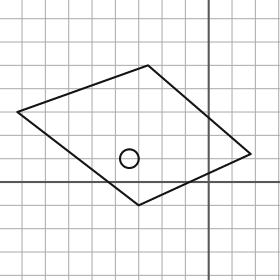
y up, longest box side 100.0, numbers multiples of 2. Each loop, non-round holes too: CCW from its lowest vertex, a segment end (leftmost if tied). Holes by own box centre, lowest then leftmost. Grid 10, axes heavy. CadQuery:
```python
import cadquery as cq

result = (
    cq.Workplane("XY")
    .moveTo(-30.0, -10.0)
    .lineTo(18.0, 12.0)
    .lineTo(-26.0, 50.0)
    .lineTo(-82.0, 30.0)
    .close()
    .moveTo(-34.0, 10.0)
    .circle(4.0)
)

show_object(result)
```